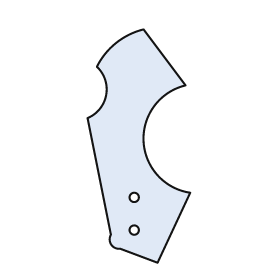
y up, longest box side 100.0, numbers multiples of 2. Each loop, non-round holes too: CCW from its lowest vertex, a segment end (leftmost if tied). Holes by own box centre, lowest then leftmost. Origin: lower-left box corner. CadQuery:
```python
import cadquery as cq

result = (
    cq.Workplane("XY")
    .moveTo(30.0, 0.0)
    .lineTo(44.0, 30.0)
    .threePointArc((24.0, 52.0), (42.0, 76.0))
    .lineTo(24.0, 100.0)
    .threePointArc((12.0, 94.0), (4.0, 84.0))
    .threePointArc((8.0, 72.0), (0.0, 62.0))
    .lineTo(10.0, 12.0)
    .threePointArc((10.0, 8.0), (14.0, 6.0))
    .close()
    .moveTo(20.0, 14.0)
    .circle(2.0)
    .moveTo(20.0, 28.0)
    .circle(2.0)
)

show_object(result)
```